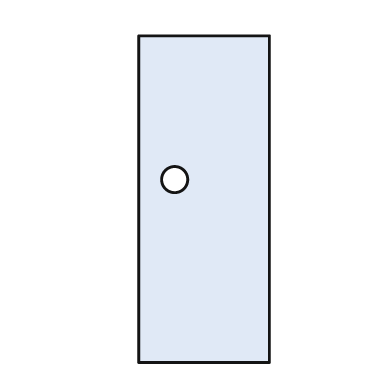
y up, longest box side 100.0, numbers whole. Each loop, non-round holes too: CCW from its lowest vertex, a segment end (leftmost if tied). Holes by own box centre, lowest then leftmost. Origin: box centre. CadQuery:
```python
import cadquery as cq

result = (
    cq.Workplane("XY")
    .moveTo(-20.0, -50.0)
    .lineTo(20.0, -50.0)
    .lineTo(20.0, 50.0)
    .lineTo(-20.0, 50.0)
    .close()
    .moveTo(-9.0, 6.0)
    .circle(4.0)
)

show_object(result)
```